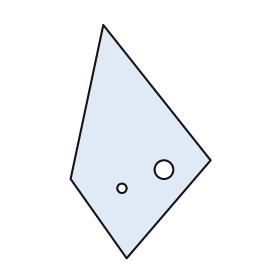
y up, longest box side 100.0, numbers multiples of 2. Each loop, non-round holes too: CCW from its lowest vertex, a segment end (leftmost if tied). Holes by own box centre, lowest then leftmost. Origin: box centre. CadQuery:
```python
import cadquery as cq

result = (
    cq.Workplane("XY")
    .moveTo(-6.0, -50.0)
    .lineTo(30.0, -8.0)
    .lineTo(-16.0, 50.0)
    .lineTo(-30.0, -16.0)
    .close()
    .moveTo(-8.0, -20.0)
    .circle(2.0)
    .moveTo(10.0, -12.0)
    .circle(4.0)
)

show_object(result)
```